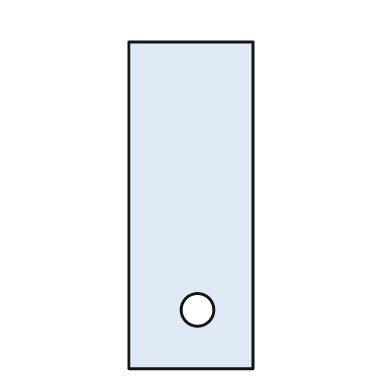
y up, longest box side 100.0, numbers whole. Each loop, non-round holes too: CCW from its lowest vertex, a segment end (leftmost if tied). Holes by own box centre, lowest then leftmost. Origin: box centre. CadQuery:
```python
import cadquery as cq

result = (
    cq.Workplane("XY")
    .moveTo(-19.0, -50.0)
    .lineTo(19.0, -50.0)
    .lineTo(19.0, 50.0)
    .lineTo(-19.0, 50.0)
    .close()
    .moveTo(2.0, -32.0)
    .circle(5.0)
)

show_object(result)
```